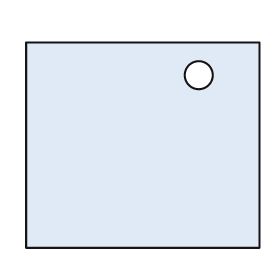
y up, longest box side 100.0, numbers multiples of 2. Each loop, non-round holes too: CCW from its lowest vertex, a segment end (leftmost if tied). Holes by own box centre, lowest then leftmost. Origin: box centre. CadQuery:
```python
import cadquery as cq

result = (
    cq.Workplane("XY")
    .moveTo(-50.0, -44.0)
    .lineTo(50.0, -44.0)
    .lineTo(50.0, 44.0)
    .lineTo(-50.0, 44.0)
    .close()
    .moveTo(24.0, 30.0)
    .circle(6.0)
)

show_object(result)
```